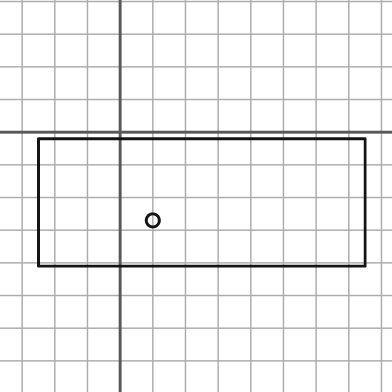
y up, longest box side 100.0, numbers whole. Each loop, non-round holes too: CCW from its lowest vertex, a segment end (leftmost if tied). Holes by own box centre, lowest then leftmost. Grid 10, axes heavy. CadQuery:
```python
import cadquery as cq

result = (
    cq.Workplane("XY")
    .moveTo(-25.0, -41.0)
    .lineTo(75.0, -41.0)
    .lineTo(75.0, -2.0)
    .lineTo(-25.0, -2.0)
    .close()
    .moveTo(10.0, -27.0)
    .circle(2.0)
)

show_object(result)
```